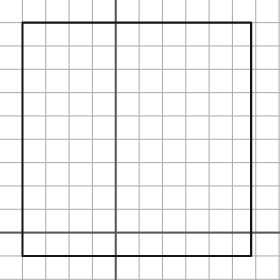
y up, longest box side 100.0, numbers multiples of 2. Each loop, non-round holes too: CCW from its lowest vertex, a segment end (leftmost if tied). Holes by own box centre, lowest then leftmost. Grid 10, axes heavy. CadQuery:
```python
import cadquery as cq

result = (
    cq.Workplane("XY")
    .moveTo(-40.0, -10.0)
    .lineTo(58.0, -10.0)
    .lineTo(58.0, 90.0)
    .lineTo(-40.0, 90.0)
    .close()
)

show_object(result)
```